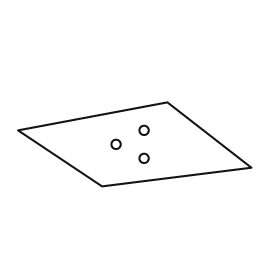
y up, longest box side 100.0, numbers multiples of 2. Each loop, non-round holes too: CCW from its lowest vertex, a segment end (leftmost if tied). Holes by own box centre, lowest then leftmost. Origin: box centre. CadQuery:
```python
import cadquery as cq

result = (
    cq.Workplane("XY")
    .moveTo(-14.0, -18.0)
    .lineTo(50.0, -10.0)
    .lineTo(14.0, 18.0)
    .lineTo(-50.0, 6.0)
    .close()
    .moveTo(4.0, -6.0)
    .circle(2.0)
    .moveTo(-8.0, 0.0)
    .circle(2.0)
    .moveTo(4.0, 6.0)
    .circle(2.0)
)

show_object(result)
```